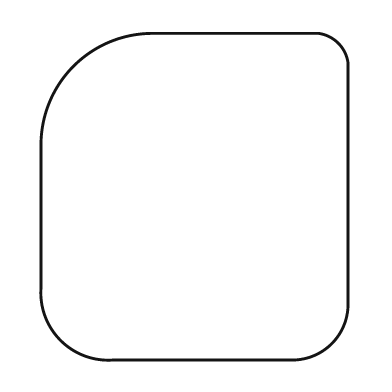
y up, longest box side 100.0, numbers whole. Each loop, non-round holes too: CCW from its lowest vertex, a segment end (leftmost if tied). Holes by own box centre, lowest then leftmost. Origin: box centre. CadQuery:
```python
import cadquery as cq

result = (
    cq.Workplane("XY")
    .moveTo(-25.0, -50.0)
    .lineTo(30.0, -50.0)
    .threePointArc((42.0, -45.0), (47.0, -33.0))
    .lineTo(47.0, 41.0)
    .threePointArc((44.0, 47.0), (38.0, 50.0))
    .lineTo(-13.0, 50.0)
    .threePointArc((-37.0, 40.0), (-47.0, 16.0))
    .lineTo(-47.0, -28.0)
    .threePointArc((-41.0, -44.0), (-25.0, -50.0))
    .close()
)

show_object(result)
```